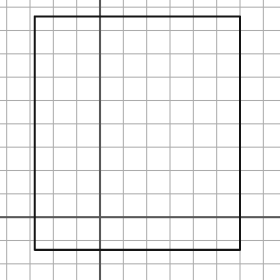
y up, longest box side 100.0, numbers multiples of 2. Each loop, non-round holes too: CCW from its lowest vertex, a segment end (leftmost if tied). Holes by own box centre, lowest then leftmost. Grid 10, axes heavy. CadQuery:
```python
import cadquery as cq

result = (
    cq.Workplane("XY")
    .moveTo(-28.0, -14.0)
    .lineTo(60.0, -14.0)
    .lineTo(60.0, 86.0)
    .lineTo(-28.0, 86.0)
    .close()
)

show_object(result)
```